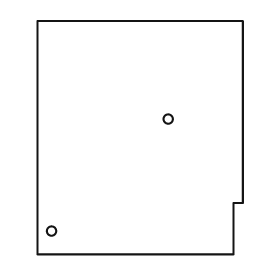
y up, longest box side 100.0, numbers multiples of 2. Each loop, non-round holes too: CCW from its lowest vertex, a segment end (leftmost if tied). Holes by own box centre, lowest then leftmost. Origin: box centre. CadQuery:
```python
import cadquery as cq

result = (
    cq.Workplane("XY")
    .moveTo(-44.0, -50.0)
    .lineTo(40.0, -50.0)
    .lineTo(40.0, -28.0)
    .lineTo(44.0, -28.0)
    .lineTo(44.0, 50.0)
    .lineTo(-44.0, 50.0)
    .close()
    .moveTo(-38.0, -40.0)
    .circle(2.0)
    .moveTo(12.0, 8.0)
    .circle(2.0)
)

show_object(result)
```